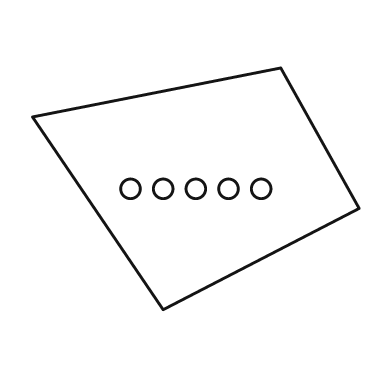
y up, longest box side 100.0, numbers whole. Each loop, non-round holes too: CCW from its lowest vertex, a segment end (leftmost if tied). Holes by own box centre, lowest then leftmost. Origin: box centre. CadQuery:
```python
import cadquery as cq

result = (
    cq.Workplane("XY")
    .moveTo(-10.0, -37.0)
    .lineTo(50.0, -6.0)
    .lineTo(26.0, 37.0)
    .lineTo(-50.0, 22.0)
    .close()
    .moveTo(-20.0, 0.0)
    .circle(3.0)
    .moveTo(-10.0, 0.0)
    .circle(3.0)
    .moveTo(0.0, 0.0)
    .circle(3.0)
    .moveTo(10.0, 0.0)
    .circle(3.0)
    .moveTo(20.0, 0.0)
    .circle(3.0)
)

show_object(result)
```